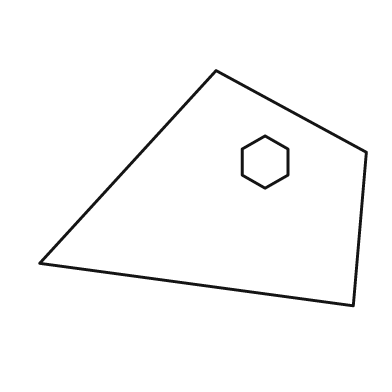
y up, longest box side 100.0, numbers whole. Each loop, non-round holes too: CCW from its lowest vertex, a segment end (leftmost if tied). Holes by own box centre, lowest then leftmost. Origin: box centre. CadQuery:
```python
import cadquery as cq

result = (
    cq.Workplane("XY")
    .moveTo(46.0, -36.0)
    .lineTo(50.0, 11.0)
    .lineTo(4.0, 36.0)
    .lineTo(-50.0, -23.0)
    .close()
    .moveTo(19.0, 0.0)
    .lineTo(26.0, 4.0)
    .lineTo(26.0, 12.0)
    .lineTo(19.0, 16.0)
    .lineTo(12.0, 12.0)
    .lineTo(12.0, 4.0)
    .close()
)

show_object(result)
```